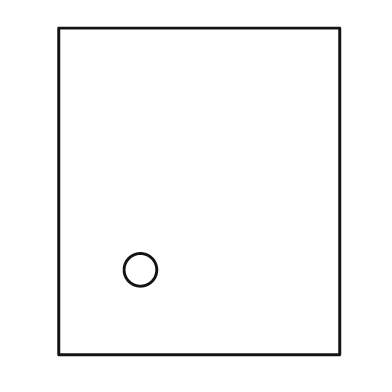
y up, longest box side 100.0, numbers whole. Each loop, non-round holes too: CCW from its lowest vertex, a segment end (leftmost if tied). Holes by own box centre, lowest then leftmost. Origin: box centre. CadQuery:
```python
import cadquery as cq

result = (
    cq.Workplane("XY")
    .moveTo(-43.0, -50.0)
    .lineTo(43.0, -50.0)
    .lineTo(43.0, 50.0)
    .lineTo(-43.0, 50.0)
    .close()
    .moveTo(-18.0, -24.0)
    .circle(5.0)
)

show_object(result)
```